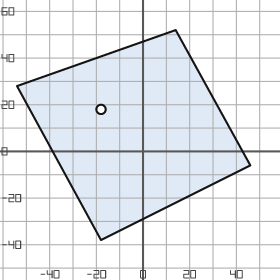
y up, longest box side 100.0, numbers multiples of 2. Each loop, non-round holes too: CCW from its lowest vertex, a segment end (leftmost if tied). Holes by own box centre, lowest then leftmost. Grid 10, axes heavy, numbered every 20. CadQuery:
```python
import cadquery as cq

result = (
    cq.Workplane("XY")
    .moveTo(-18.0, -38.0)
    .lineTo(46.0, -6.0)
    .lineTo(14.0, 52.0)
    .lineTo(-54.0, 28.0)
    .close()
    .moveTo(-18.0, 18.0)
    .circle(2.0)
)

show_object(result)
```